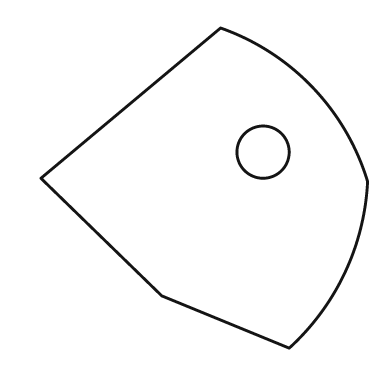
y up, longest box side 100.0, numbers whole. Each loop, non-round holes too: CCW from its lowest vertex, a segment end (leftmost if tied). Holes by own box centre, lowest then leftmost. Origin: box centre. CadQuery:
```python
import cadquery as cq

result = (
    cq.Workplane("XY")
    .moveTo(26.0, -49.0)
    .threePointArc((43.0, -26.0), (50.0, 2.0))
    .threePointArc((33.0, 31.0), (5.0, 49.0))
    .lineTo(-50.0, 3.0)
    .lineTo(-13.0, -33.0)
    .close()
    .moveTo(18.0, 11.0)
    .circle(8.0)
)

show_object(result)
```